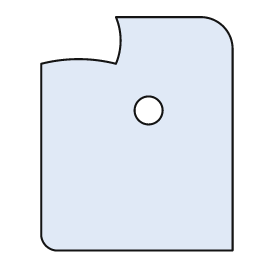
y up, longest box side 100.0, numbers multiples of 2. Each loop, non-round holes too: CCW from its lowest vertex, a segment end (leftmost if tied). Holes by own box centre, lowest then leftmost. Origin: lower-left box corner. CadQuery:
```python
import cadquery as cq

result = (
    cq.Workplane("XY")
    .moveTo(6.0, 0.0)
    .lineTo(82.0, 0.0)
    .lineTo(82.0, 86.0)
    .threePointArc((78.0, 96.0), (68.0, 100.0))
    .lineTo(32.0, 100.0)
    .threePointArc((34.0, 90.0), (32.0, 80.0))
    .threePointArc((16.0, 82.0), (0.0, 80.0))
    .lineTo(0.0, 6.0)
    .threePointArc((2.0, 2.0), (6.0, 0.0))
    .close()
    .moveTo(46.0, 60.0)
    .circle(6.0)
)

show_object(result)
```